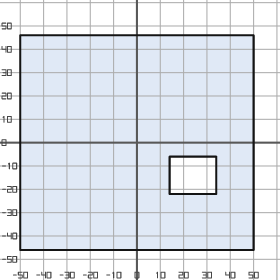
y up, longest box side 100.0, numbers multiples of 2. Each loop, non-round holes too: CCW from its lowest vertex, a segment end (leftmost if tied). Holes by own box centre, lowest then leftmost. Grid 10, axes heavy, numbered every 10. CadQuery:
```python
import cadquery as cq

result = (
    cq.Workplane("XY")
    .moveTo(-50.0, -46.0)
    .lineTo(50.0, -46.0)
    .lineTo(50.0, 46.0)
    .lineTo(-50.0, 46.0)
    .close()
    .moveTo(14.0, -22.0)
    .lineTo(34.0, -22.0)
    .lineTo(34.0, -6.0)
    .lineTo(14.0, -6.0)
    .close()
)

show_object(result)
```